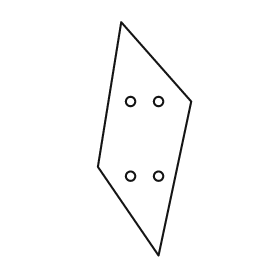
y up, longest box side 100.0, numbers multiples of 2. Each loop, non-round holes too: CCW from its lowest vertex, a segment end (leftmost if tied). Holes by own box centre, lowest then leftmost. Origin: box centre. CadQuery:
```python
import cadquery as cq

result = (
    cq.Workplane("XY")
    .moveTo(6.0, -50.0)
    .lineTo(20.0, 16.0)
    .lineTo(-10.0, 50.0)
    .lineTo(-20.0, -12.0)
    .close()
    .moveTo(-6.0, -16.0)
    .circle(2.0)
    .moveTo(6.0, -16.0)
    .circle(2.0)
    .moveTo(-6.0, 16.0)
    .circle(2.0)
    .moveTo(6.0, 16.0)
    .circle(2.0)
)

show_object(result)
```